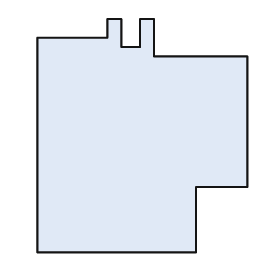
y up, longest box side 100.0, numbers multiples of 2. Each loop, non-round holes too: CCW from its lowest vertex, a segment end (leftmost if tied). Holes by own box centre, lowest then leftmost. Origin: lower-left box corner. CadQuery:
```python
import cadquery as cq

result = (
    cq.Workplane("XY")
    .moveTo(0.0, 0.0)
    .lineTo(68.0, 0.0)
    .lineTo(68.0, 28.0)
    .lineTo(90.0, 28.0)
    .lineTo(90.0, 84.0)
    .lineTo(50.0, 84.0)
    .lineTo(50.0, 100.0)
    .lineTo(44.0, 100.0)
    .lineTo(44.0, 88.0)
    .lineTo(36.0, 88.0)
    .lineTo(36.0, 100.0)
    .lineTo(30.0, 100.0)
    .lineTo(30.0, 92.0)
    .lineTo(0.0, 92.0)
    .close()
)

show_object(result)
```